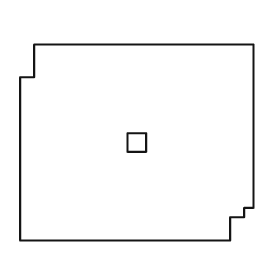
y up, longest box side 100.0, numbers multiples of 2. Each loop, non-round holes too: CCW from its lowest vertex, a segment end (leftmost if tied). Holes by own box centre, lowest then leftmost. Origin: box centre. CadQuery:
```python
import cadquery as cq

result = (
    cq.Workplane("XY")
    .moveTo(-50.0, -42.0)
    .lineTo(40.0, -42.0)
    .lineTo(40.0, -32.0)
    .lineTo(46.0, -32.0)
    .lineTo(46.0, -28.0)
    .lineTo(50.0, -28.0)
    .lineTo(50.0, 42.0)
    .lineTo(-44.0, 42.0)
    .lineTo(-44.0, 28.0)
    .lineTo(-50.0, 28.0)
    .close()
    .moveTo(-4.0, -4.0)
    .lineTo(4.0, -4.0)
    .lineTo(4.0, 4.0)
    .lineTo(-4.0, 4.0)
    .close()
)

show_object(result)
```